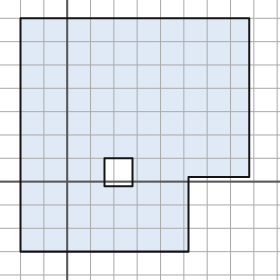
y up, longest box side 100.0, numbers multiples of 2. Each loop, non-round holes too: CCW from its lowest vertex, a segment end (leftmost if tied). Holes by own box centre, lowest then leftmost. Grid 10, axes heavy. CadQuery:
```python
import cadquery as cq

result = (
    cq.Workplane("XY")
    .moveTo(-20.0, -30.0)
    .lineTo(52.0, -30.0)
    .lineTo(52.0, 2.0)
    .lineTo(78.0, 2.0)
    .lineTo(78.0, 70.0)
    .lineTo(-20.0, 70.0)
    .close()
    .moveTo(16.0, -2.0)
    .lineTo(28.0, -2.0)
    .lineTo(28.0, 10.0)
    .lineTo(16.0, 10.0)
    .close()
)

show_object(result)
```